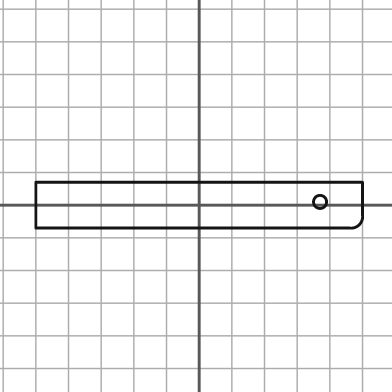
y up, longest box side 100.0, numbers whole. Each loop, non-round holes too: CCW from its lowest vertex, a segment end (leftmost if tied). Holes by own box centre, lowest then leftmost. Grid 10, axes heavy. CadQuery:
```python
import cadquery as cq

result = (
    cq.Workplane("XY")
    .moveTo(-50.0, -7.0)
    .lineTo(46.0, -7.0)
    .threePointArc((49.0, -6.0), (50.0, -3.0))
    .lineTo(50.0, 7.0)
    .lineTo(-50.0, 7.0)
    .close()
    .moveTo(37.0, 1.0)
    .circle(2.0)
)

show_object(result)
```